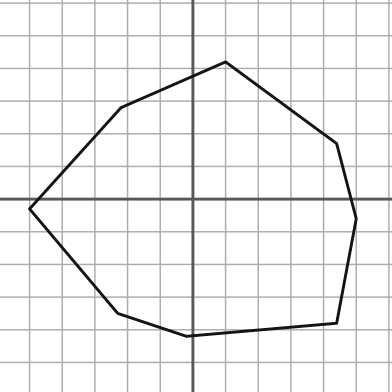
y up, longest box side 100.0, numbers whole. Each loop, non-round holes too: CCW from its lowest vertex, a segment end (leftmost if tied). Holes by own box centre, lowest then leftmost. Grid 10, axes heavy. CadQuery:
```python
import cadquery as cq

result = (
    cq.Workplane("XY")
    .moveTo(-2.0, -42.0)
    .lineTo(44.0, -38.0)
    .lineTo(50.0, -6.0)
    .lineTo(44.0, 17.0)
    .lineTo(10.0, 42.0)
    .lineTo(-22.0, 28.0)
    .lineTo(-50.0, -3.0)
    .lineTo(-23.0, -35.0)
    .close()
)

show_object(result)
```